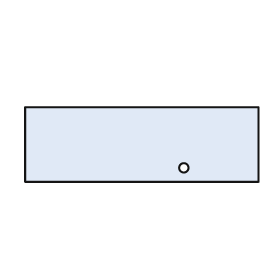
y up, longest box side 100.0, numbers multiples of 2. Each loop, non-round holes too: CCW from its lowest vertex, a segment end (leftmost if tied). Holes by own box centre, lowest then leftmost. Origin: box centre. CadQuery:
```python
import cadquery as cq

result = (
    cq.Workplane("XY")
    .moveTo(-50.0, -16.0)
    .lineTo(50.0, -16.0)
    .lineTo(50.0, 16.0)
    .lineTo(-50.0, 16.0)
    .close()
    .moveTo(18.0, -10.0)
    .circle(2.0)
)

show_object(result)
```